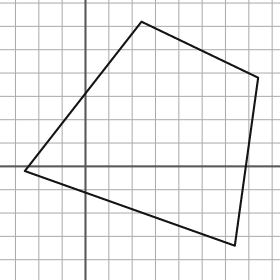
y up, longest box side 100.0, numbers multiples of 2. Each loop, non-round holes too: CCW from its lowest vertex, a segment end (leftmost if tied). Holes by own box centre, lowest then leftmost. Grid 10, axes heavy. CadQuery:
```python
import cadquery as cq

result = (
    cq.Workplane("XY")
    .moveTo(64.0, -34.0)
    .lineTo(74.0, 38.0)
    .lineTo(24.0, 62.0)
    .lineTo(-26.0, -2.0)
    .close()
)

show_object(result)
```